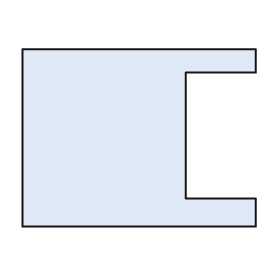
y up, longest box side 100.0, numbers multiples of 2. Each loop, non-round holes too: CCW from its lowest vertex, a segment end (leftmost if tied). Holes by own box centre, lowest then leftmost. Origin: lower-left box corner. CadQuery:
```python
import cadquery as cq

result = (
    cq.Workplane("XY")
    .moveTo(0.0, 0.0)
    .lineTo(100.0, 0.0)
    .lineTo(100.0, 12.0)
    .lineTo(70.0, 12.0)
    .lineTo(70.0, 66.0)
    .lineTo(100.0, 66.0)
    .lineTo(100.0, 76.0)
    .lineTo(0.0, 76.0)
    .close()
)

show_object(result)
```